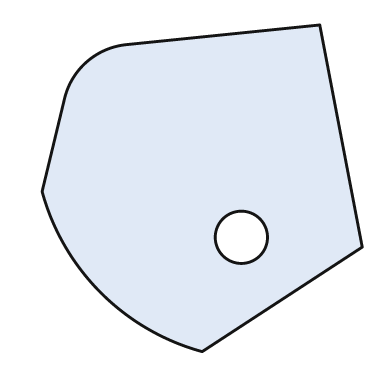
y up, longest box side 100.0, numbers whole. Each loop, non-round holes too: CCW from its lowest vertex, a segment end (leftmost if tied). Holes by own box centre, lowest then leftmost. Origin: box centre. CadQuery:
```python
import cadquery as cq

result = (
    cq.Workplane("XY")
    .moveTo(0.0, -50.0)
    .lineTo(49.0, -18.0)
    .lineTo(36.0, 50.0)
    .lineTo(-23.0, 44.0)
    .threePointArc((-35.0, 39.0), (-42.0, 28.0))
    .lineTo(-49.0, -1.0)
    .threePointArc((-31.0, -32.0), (0.0, -50.0))
    .close()
    .moveTo(12.0, -15.0)
    .circle(8.0)
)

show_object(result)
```